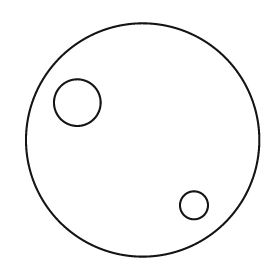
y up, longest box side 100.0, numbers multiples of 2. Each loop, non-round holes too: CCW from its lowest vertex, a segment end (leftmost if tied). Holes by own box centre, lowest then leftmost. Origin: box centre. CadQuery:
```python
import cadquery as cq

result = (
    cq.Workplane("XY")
    .moveTo(0.0, 0.0)
    .circle(50.0)
    .moveTo(22.0, -28.0)
    .circle(6.0)
    .moveTo(-28.0, 16.0)
    .circle(10.0)
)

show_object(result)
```